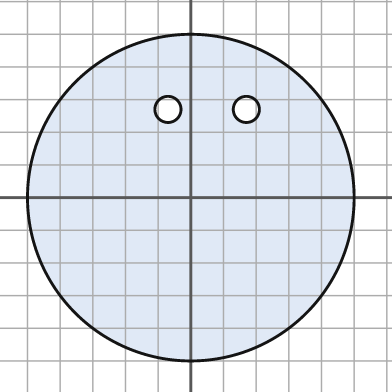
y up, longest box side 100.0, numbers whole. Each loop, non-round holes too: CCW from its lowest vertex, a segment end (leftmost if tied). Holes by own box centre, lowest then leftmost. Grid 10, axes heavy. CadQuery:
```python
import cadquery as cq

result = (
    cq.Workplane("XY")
    .moveTo(0.0, 0.0)
    .circle(50.0)
    .moveTo(-7.0, 27.0)
    .circle(4.0)
    .moveTo(17.0, 27.0)
    .circle(4.0)
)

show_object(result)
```